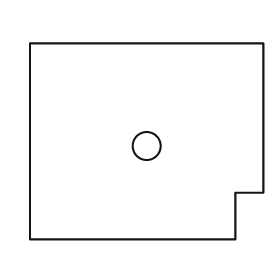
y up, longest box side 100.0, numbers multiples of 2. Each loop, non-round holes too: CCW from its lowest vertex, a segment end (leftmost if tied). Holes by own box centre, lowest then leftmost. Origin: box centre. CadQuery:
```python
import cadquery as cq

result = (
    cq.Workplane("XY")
    .moveTo(-50.0, -42.0)
    .lineTo(38.0, -42.0)
    .lineTo(38.0, -22.0)
    .lineTo(50.0, -22.0)
    .lineTo(50.0, 42.0)
    .lineTo(-50.0, 42.0)
    .close()
    .moveTo(0.0, -2.0)
    .circle(6.0)
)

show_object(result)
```